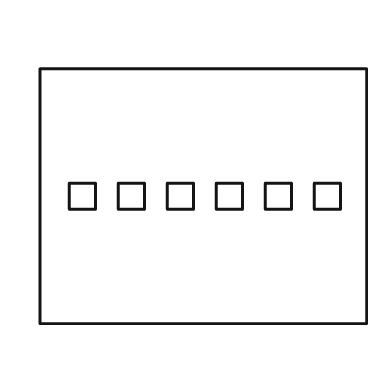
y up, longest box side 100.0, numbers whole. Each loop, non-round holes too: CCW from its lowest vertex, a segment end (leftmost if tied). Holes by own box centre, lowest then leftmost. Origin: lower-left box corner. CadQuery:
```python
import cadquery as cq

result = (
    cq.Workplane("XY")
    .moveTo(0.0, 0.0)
    .lineTo(100.0, 0.0)
    .lineTo(100.0, 78.0)
    .lineTo(0.0, 78.0)
    .close()
    .moveTo(9.0, 35.0)
    .lineTo(17.0, 35.0)
    .lineTo(17.0, 43.0)
    .lineTo(9.0, 43.0)
    .close()
    .moveTo(24.0, 35.0)
    .lineTo(32.0, 35.0)
    .lineTo(32.0, 43.0)
    .lineTo(24.0, 43.0)
    .close()
    .moveTo(39.0, 35.0)
    .lineTo(47.0, 35.0)
    .lineTo(47.0, 43.0)
    .lineTo(39.0, 43.0)
    .close()
    .moveTo(54.0, 35.0)
    .lineTo(62.0, 35.0)
    .lineTo(62.0, 43.0)
    .lineTo(54.0, 43.0)
    .close()
    .moveTo(69.0, 35.0)
    .lineTo(77.0, 35.0)
    .lineTo(77.0, 43.0)
    .lineTo(69.0, 43.0)
    .close()
    .moveTo(84.0, 35.0)
    .lineTo(92.0, 35.0)
    .lineTo(92.0, 43.0)
    .lineTo(84.0, 43.0)
    .close()
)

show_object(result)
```